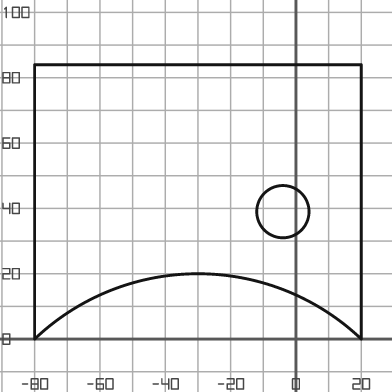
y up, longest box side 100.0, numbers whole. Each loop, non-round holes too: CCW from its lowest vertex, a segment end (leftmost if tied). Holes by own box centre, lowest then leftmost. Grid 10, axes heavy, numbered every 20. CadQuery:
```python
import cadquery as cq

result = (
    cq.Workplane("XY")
    .moveTo(-80.0, 0.0)
    .threePointArc((-30.0, 20.0), (20.0, 0.0))
    .lineTo(20.0, 84.0)
    .lineTo(-80.0, 84.0)
    .close()
    .moveTo(-4.0, 39.0)
    .circle(8.0)
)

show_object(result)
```